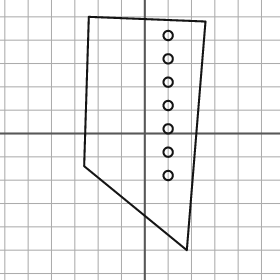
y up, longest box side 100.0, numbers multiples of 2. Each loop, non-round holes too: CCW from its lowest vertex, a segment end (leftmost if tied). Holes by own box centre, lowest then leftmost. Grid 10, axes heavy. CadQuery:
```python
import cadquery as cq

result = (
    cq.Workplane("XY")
    .moveTo(18.0, -50.0)
    .lineTo(26.0, 48.0)
    .lineTo(-24.0, 50.0)
    .lineTo(-26.0, -14.0)
    .close()
    .moveTo(10.0, -18.0)
    .circle(2.0)
    .moveTo(10.0, -8.0)
    .circle(2.0)
    .moveTo(10.0, 2.0)
    .circle(2.0)
    .moveTo(10.0, 12.0)
    .circle(2.0)
    .moveTo(10.0, 22.0)
    .circle(2.0)
    .moveTo(10.0, 32.0)
    .circle(2.0)
    .moveTo(10.0, 42.0)
    .circle(2.0)
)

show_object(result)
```